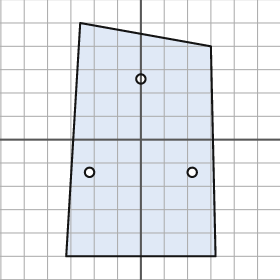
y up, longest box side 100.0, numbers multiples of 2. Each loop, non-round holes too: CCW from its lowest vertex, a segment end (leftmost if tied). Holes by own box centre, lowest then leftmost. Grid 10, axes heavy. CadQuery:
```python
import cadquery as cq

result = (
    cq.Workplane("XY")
    .moveTo(-32.0, -50.0)
    .lineTo(32.0, -50.0)
    .lineTo(30.0, 40.0)
    .lineTo(-26.0, 50.0)
    .close()
    .moveTo(-22.0, -14.0)
    .circle(2.0)
    .moveTo(22.0, -14.0)
    .circle(2.0)
    .moveTo(0.0, 26.0)
    .circle(2.0)
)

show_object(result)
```